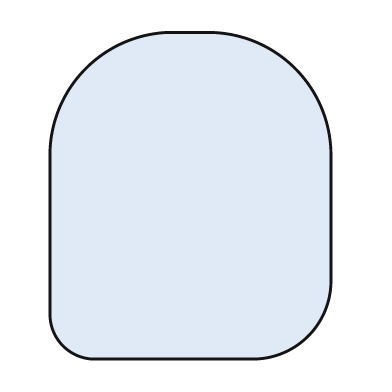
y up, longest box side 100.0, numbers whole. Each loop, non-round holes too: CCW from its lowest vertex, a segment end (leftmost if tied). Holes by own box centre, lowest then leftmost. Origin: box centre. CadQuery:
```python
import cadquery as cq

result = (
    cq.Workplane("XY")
    .moveTo(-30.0, -50.0)
    .lineTo(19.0, -50.0)
    .threePointArc((36.0, -43.0), (43.0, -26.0))
    .lineTo(43.0, 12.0)
    .threePointArc((32.0, 39.0), (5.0, 50.0))
    .lineTo(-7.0, 50.0)
    .threePointArc((-32.0, 39.0), (-43.0, 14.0))
    .lineTo(-43.0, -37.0)
    .threePointArc((-39.0, -46.0), (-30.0, -50.0))
    .close()
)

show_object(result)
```